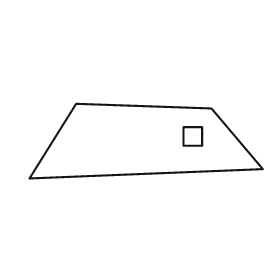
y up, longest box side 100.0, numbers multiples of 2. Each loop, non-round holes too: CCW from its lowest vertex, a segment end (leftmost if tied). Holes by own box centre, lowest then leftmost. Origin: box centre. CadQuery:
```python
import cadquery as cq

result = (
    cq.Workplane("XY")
    .moveTo(-50.0, -16.0)
    .lineTo(50.0, -12.0)
    .lineTo(28.0, 14.0)
    .lineTo(-30.0, 16.0)
    .close()
    .moveTo(16.0, -2.0)
    .lineTo(24.0, -2.0)
    .lineTo(24.0, 6.0)
    .lineTo(16.0, 6.0)
    .close()
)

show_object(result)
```